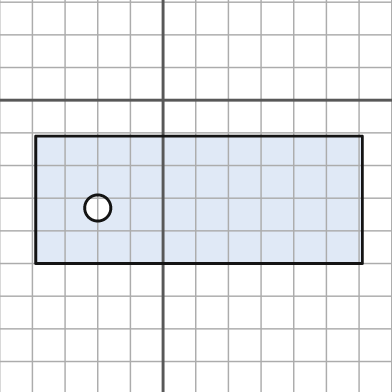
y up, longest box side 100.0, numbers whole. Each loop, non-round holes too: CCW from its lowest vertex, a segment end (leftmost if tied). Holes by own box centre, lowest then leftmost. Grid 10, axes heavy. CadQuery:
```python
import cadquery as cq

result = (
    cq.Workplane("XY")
    .moveTo(-39.0, -50.0)
    .lineTo(61.0, -50.0)
    .lineTo(61.0, -11.0)
    .lineTo(-39.0, -11.0)
    .close()
    .moveTo(-20.0, -33.0)
    .circle(4.0)
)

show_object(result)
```